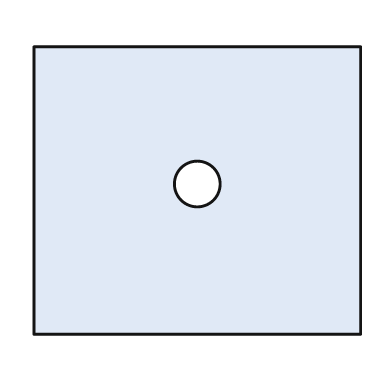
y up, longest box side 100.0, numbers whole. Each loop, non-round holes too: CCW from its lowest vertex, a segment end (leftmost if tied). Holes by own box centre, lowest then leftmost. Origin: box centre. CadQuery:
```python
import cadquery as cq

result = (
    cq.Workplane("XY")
    .moveTo(-50.0, -44.0)
    .lineTo(50.0, -44.0)
    .lineTo(50.0, 44.0)
    .lineTo(-50.0, 44.0)
    .close()
    .moveTo(0.0, 2.0)
    .circle(7.0)
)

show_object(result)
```